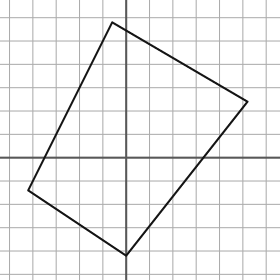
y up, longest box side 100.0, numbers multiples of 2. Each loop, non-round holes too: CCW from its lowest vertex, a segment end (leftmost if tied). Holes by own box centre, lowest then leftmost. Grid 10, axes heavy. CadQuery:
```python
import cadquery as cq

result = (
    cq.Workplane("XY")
    .moveTo(0.0, -42.0)
    .lineTo(52.0, 24.0)
    .lineTo(-6.0, 58.0)
    .lineTo(-42.0, -14.0)
    .close()
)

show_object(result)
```